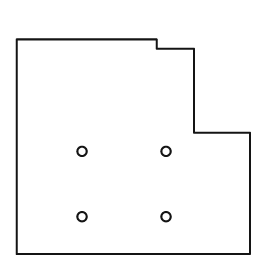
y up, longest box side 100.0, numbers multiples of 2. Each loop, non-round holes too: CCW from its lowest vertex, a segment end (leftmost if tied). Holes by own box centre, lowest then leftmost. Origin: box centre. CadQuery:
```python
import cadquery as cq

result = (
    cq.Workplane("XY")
    .moveTo(-50.0, -46.0)
    .lineTo(50.0, -46.0)
    .lineTo(50.0, 6.0)
    .lineTo(26.0, 6.0)
    .lineTo(26.0, 42.0)
    .lineTo(10.0, 42.0)
    .lineTo(10.0, 46.0)
    .lineTo(-50.0, 46.0)
    .close()
    .moveTo(-22.0, -30.0)
    .circle(2.0)
    .moveTo(14.0, -30.0)
    .circle(2.0)
    .moveTo(-22.0, -2.0)
    .circle(2.0)
    .moveTo(14.0, -2.0)
    .circle(2.0)
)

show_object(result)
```